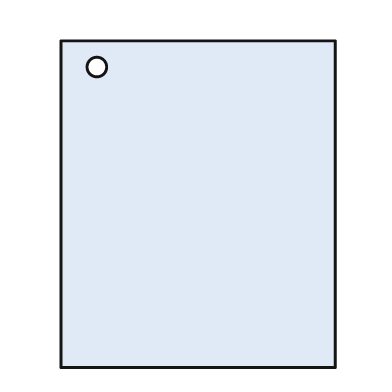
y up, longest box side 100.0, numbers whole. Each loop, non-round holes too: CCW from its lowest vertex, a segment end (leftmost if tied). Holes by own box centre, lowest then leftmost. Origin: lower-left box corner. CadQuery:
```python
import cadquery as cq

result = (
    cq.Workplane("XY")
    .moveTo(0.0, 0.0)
    .lineTo(84.0, 0.0)
    .lineTo(84.0, 100.0)
    .lineTo(0.0, 100.0)
    .close()
    .moveTo(11.0, 92.0)
    .circle(3.0)
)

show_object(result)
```